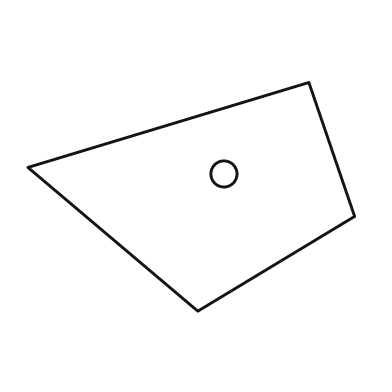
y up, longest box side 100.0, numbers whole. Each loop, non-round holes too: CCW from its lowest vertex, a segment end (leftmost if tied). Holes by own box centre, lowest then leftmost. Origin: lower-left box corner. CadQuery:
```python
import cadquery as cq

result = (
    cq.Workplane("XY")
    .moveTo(52.0, 0.0)
    .lineTo(100.0, 29.0)
    .lineTo(86.0, 70.0)
    .lineTo(0.0, 44.0)
    .close()
    .moveTo(60.0, 42.0)
    .circle(4.0)
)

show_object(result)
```